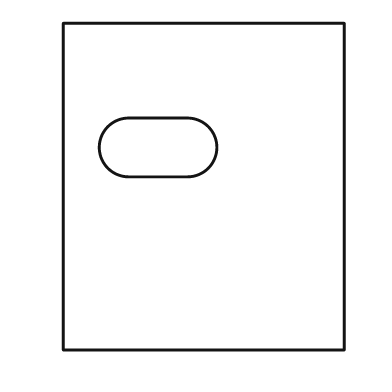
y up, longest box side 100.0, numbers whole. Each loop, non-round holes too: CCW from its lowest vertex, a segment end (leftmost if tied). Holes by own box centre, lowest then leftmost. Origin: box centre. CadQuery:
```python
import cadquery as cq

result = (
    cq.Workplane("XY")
    .moveTo(-43.0, -50.0)
    .lineTo(43.0, -50.0)
    .lineTo(43.0, 50.0)
    .lineTo(-43.0, 50.0)
    .close()
    .moveTo(-23.0, 3.0)
    .lineTo(-5.0, 3.0)
    .threePointArc((4.0, 12.0), (-5.0, 21.0))
    .lineTo(-23.0, 21.0)
    .threePointArc((-32.0, 12.0), (-23.0, 3.0))
    .close()
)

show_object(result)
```